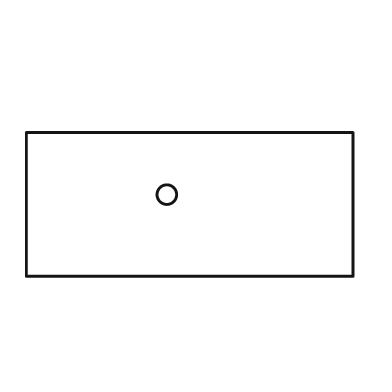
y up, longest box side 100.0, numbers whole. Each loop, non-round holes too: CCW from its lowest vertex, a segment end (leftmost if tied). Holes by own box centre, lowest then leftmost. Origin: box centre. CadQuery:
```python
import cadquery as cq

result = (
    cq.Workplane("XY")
    .moveTo(-50.0, -22.0)
    .lineTo(50.0, -22.0)
    .lineTo(50.0, 22.0)
    .lineTo(-50.0, 22.0)
    .close()
    .moveTo(-7.0, 3.0)
    .circle(3.0)
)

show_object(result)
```